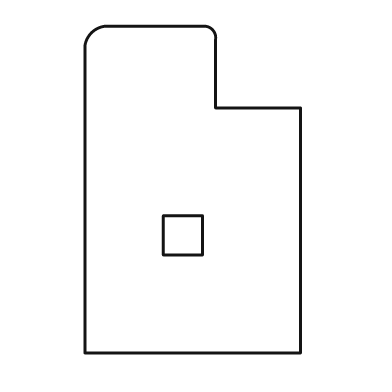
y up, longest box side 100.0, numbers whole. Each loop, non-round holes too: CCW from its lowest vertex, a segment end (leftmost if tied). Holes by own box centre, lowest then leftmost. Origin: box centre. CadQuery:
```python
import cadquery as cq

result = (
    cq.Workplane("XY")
    .moveTo(-33.0, -50.0)
    .lineTo(33.0, -50.0)
    .lineTo(33.0, 25.0)
    .lineTo(7.0, 25.0)
    .lineTo(7.0, 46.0)
    .threePointArc((6.0, 49.0), (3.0, 50.0))
    .lineTo(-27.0, 50.0)
    .threePointArc((-31.0, 48.0), (-33.0, 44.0))
    .close()
    .moveTo(-9.0, -20.0)
    .lineTo(3.0, -20.0)
    .lineTo(3.0, -8.0)
    .lineTo(-9.0, -8.0)
    .close()
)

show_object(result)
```